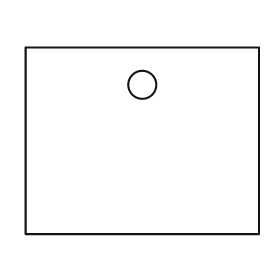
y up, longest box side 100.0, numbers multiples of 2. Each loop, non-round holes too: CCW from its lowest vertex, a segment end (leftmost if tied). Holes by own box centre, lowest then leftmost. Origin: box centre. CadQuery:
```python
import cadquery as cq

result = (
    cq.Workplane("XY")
    .moveTo(-50.0, -40.0)
    .lineTo(50.0, -40.0)
    .lineTo(50.0, 40.0)
    .lineTo(-50.0, 40.0)
    .close()
    .moveTo(0.0, 24.0)
    .circle(6.0)
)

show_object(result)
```